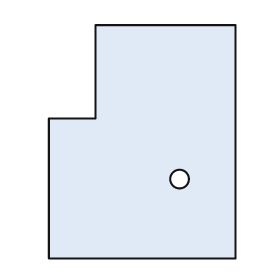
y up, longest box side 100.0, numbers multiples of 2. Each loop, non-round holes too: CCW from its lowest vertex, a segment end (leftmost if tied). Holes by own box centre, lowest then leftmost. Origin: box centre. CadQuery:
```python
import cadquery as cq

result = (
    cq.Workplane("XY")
    .moveTo(-40.0, -50.0)
    .lineTo(40.0, -50.0)
    .lineTo(40.0, 50.0)
    .lineTo(-20.0, 50.0)
    .lineTo(-20.0, 10.0)
    .lineTo(-40.0, 10.0)
    .close()
    .moveTo(16.0, -16.0)
    .circle(4.0)
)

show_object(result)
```